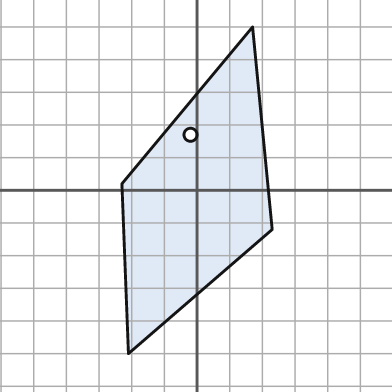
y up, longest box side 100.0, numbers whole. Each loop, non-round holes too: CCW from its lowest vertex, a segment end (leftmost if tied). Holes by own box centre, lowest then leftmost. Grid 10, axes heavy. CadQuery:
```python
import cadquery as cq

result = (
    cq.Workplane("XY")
    .moveTo(-21.0, -50.0)
    .lineTo(23.0, -12.0)
    .lineTo(17.0, 50.0)
    .lineTo(-23.0, 2.0)
    .close()
    .moveTo(-2.0, 17.0)
    .circle(2.0)
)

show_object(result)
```